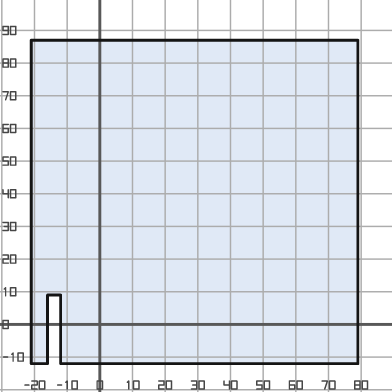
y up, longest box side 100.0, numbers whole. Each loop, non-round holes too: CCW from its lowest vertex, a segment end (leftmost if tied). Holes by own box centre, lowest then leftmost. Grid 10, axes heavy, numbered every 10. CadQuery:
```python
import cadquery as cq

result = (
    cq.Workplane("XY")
    .moveTo(-21.0, -12.0)
    .lineTo(-16.0, -12.0)
    .lineTo(-16.0, 9.0)
    .lineTo(-12.0, 9.0)
    .lineTo(-12.0, -12.0)
    .lineTo(79.0, -12.0)
    .lineTo(79.0, 87.0)
    .lineTo(-21.0, 87.0)
    .close()
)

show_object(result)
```